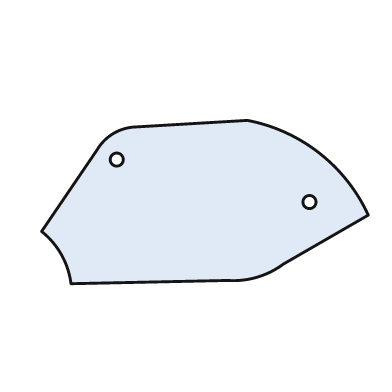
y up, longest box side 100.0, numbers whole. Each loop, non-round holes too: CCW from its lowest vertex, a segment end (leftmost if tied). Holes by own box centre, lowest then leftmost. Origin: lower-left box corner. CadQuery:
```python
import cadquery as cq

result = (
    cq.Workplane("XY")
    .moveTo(9.0, 0.0)
    .lineTo(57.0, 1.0)
    .threePointArc((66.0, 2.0), (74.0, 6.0))
    .lineTo(100.0, 21.0)
    .threePointArc((85.0, 40.0), (63.0, 50.0))
    .lineTo(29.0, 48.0)
    .threePointArc((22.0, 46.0), (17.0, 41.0))
    .lineTo(0.0, 16.0)
    .threePointArc((6.0, 9.0), (9.0, 0.0))
    .close()
    .moveTo(82.0, 25.0)
    .circle(2.0)
    .moveTo(23.0, 38.0)
    .circle(2.0)
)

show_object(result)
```